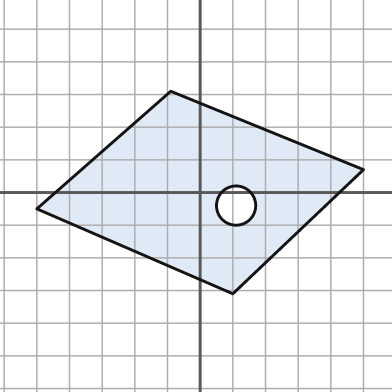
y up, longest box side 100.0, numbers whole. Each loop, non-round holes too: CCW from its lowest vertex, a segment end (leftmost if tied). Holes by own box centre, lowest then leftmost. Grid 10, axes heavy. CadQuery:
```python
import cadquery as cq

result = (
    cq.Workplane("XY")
    .moveTo(10.0, -31.0)
    .lineTo(50.0, 7.0)
    .lineTo(-9.0, 31.0)
    .lineTo(-50.0, -5.0)
    .close()
    .moveTo(11.0, -4.0)
    .circle(6.0)
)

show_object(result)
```